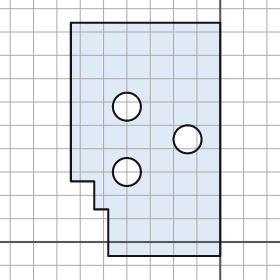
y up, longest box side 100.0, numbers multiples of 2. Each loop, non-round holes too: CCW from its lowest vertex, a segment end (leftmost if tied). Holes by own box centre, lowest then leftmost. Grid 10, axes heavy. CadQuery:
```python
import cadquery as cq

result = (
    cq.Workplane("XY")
    .moveTo(-48.0, -6.0)
    .lineTo(0.0, -6.0)
    .lineTo(0.0, 94.0)
    .lineTo(-64.0, 94.0)
    .lineTo(-64.0, 26.0)
    .lineTo(-54.0, 26.0)
    .lineTo(-54.0, 14.0)
    .lineTo(-48.0, 14.0)
    .close()
    .moveTo(-40.0, 30.0)
    .circle(6.0)
    .moveTo(-14.0, 44.0)
    .circle(6.0)
    .moveTo(-40.0, 58.0)
    .circle(6.0)
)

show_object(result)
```